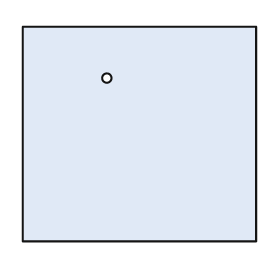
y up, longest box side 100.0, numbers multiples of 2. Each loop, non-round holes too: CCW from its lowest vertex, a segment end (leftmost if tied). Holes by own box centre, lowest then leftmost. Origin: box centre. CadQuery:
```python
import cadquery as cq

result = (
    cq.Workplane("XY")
    .moveTo(-50.0, -46.0)
    .lineTo(50.0, -46.0)
    .lineTo(50.0, 46.0)
    .lineTo(-50.0, 46.0)
    .close()
    .moveTo(-14.0, 24.0)
    .circle(2.0)
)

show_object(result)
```